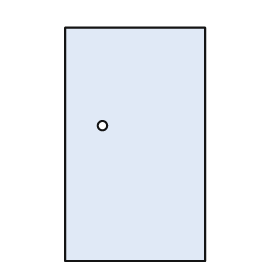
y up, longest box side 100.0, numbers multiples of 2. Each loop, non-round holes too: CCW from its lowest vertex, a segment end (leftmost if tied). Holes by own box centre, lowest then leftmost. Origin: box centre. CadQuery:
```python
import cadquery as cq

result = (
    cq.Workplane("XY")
    .moveTo(-30.0, -50.0)
    .lineTo(30.0, -50.0)
    .lineTo(30.0, 50.0)
    .lineTo(-30.0, 50.0)
    .close()
    .moveTo(-14.0, 8.0)
    .circle(2.0)
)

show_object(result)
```